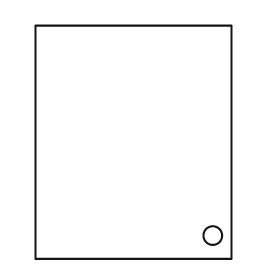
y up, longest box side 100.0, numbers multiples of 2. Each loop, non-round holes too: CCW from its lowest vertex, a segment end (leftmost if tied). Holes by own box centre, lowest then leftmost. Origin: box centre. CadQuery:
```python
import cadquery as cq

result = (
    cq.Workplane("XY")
    .moveTo(-42.0, -50.0)
    .lineTo(42.0, -50.0)
    .lineTo(42.0, 50.0)
    .lineTo(-42.0, 50.0)
    .close()
    .moveTo(34.0, -40.0)
    .circle(4.0)
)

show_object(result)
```